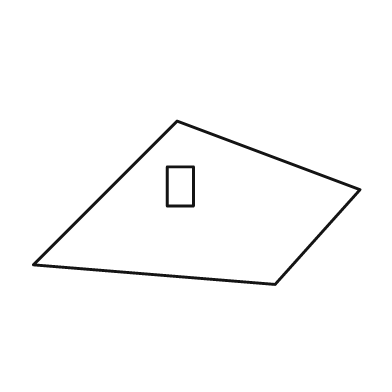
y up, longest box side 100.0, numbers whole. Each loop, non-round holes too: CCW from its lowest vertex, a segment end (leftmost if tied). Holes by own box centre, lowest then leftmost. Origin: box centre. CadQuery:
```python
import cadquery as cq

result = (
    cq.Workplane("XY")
    .moveTo(24.0, -25.0)
    .lineTo(50.0, 4.0)
    .lineTo(-6.0, 25.0)
    .lineTo(-50.0, -19.0)
    .close()
    .moveTo(-9.0, -1.0)
    .lineTo(-1.0, -1.0)
    .lineTo(-1.0, 11.0)
    .lineTo(-9.0, 11.0)
    .close()
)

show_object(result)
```